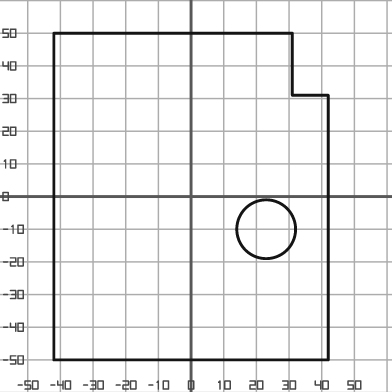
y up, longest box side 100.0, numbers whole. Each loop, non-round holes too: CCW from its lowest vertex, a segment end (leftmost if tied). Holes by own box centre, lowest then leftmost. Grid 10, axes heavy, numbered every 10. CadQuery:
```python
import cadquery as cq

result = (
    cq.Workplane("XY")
    .moveTo(-42.0, -50.0)
    .lineTo(42.0, -50.0)
    .lineTo(42.0, 31.0)
    .lineTo(31.0, 31.0)
    .lineTo(31.0, 50.0)
    .lineTo(-42.0, 50.0)
    .close()
    .moveTo(23.0, -10.0)
    .circle(9.0)
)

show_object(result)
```